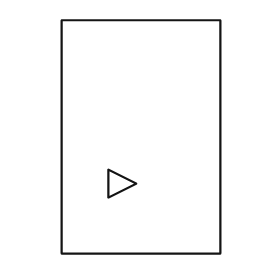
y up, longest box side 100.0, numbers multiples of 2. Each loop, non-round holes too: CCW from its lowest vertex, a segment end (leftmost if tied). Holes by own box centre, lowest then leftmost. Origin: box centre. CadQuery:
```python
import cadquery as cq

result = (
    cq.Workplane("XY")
    .moveTo(-34.0, -50.0)
    .lineTo(34.0, -50.0)
    .lineTo(34.0, 50.0)
    .lineTo(-34.0, 50.0)
    .close()
    .moveTo(-14.0, -26.0)
    .lineTo(-2.0, -20.0)
    .lineTo(-14.0, -14.0)
    .close()
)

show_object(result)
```